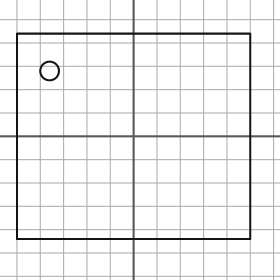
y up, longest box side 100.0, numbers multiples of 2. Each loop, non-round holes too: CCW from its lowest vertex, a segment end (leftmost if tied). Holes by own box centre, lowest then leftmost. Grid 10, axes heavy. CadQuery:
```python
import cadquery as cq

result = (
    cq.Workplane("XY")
    .moveTo(-50.0, -44.0)
    .lineTo(50.0, -44.0)
    .lineTo(50.0, 44.0)
    .lineTo(-50.0, 44.0)
    .close()
    .moveTo(-36.0, 28.0)
    .circle(4.0)
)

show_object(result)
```